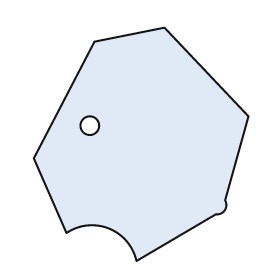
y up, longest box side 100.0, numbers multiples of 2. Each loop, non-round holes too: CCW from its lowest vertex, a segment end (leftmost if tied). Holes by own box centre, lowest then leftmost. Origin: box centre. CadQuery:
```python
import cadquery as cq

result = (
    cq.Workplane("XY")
    .moveTo(-2.0, -50.0)
    .lineTo(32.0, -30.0)
    .threePointArc((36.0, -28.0), (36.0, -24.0))
    .lineTo(46.0, 12.0)
    .lineTo(10.0, 50.0)
    .lineTo(-20.0, 44.0)
    .lineTo(-46.0, -6.0)
    .lineTo(-32.0, -38.0)
    .threePointArc((-14.0, -36.0), (-2.0, -50.0))
    .close()
    .moveTo(-22.0, 8.0)
    .circle(4.0)
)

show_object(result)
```